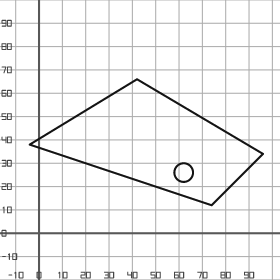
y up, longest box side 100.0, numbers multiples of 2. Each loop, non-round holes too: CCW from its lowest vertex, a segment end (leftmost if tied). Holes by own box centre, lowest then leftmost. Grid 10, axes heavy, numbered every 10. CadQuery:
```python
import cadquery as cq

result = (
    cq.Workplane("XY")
    .moveTo(74.0, 12.0)
    .lineTo(96.0, 34.0)
    .lineTo(42.0, 66.0)
    .lineTo(-4.0, 38.0)
    .close()
    .moveTo(62.0, 26.0)
    .circle(4.0)
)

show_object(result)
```